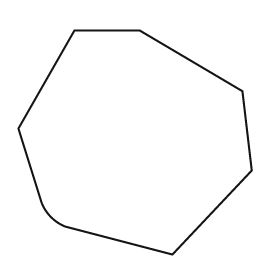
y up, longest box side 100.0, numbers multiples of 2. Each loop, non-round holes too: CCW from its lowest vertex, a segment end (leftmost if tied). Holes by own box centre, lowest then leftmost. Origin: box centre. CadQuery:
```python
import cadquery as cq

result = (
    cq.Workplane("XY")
    .moveTo(16.0, -48.0)
    .lineTo(50.0, -12.0)
    .lineTo(46.0, 22.0)
    .lineTo(2.0, 48.0)
    .lineTo(-26.0, 48.0)
    .lineTo(-50.0, 6.0)
    .lineTo(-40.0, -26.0)
    .threePointArc((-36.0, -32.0), (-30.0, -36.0))
    .close()
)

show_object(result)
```